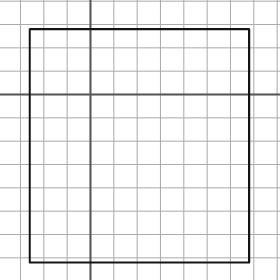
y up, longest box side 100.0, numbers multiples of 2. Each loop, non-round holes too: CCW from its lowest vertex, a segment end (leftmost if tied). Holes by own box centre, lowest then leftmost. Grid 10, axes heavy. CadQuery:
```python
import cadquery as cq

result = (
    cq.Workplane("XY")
    .moveTo(-26.0, -72.0)
    .lineTo(68.0, -72.0)
    .lineTo(68.0, 28.0)
    .lineTo(-26.0, 28.0)
    .close()
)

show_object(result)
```